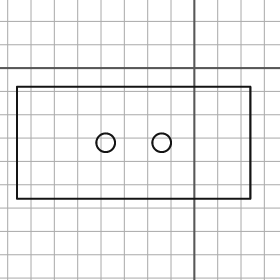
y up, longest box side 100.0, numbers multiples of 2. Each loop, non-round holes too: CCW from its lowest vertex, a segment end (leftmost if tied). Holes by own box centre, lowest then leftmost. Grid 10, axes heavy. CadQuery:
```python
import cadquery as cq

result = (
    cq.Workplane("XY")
    .moveTo(-76.0, -56.0)
    .lineTo(24.0, -56.0)
    .lineTo(24.0, -8.0)
    .lineTo(-76.0, -8.0)
    .close()
    .moveTo(-38.0, -32.0)
    .circle(4.0)
    .moveTo(-14.0, -32.0)
    .circle(4.0)
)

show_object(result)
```